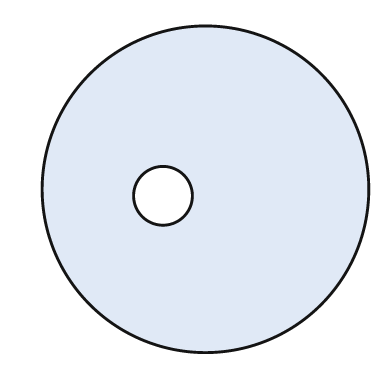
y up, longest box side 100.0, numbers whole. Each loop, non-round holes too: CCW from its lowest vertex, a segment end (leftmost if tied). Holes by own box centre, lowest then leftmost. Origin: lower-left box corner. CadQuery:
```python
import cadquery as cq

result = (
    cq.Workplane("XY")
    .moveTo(50.0, 50.0)
    .circle(50.0)
    .moveTo(37.0, 48.0)
    .circle(9.0)
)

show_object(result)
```